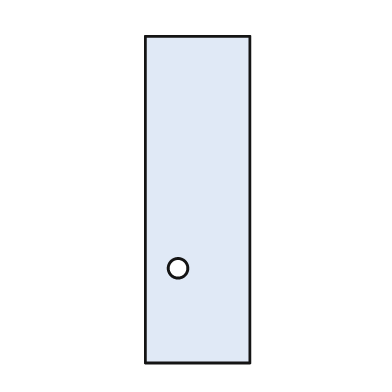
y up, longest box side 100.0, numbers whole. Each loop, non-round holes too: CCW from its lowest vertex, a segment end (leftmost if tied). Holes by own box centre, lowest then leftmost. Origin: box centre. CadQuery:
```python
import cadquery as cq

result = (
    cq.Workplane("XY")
    .moveTo(-16.0, -50.0)
    .lineTo(16.0, -50.0)
    .lineTo(16.0, 50.0)
    .lineTo(-16.0, 50.0)
    .close()
    .moveTo(-6.0, -21.0)
    .circle(3.0)
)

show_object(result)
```